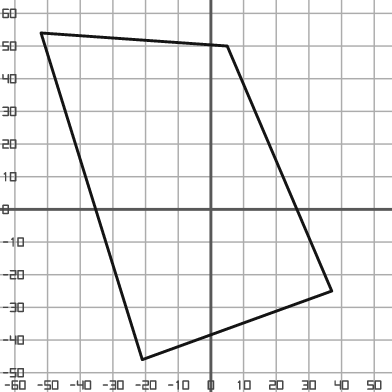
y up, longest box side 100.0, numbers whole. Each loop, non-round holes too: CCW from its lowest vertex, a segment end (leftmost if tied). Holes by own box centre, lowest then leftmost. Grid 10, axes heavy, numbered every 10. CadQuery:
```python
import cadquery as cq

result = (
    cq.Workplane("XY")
    .moveTo(-21.0, -46.0)
    .lineTo(37.0, -25.0)
    .lineTo(5.0, 50.0)
    .lineTo(-52.0, 54.0)
    .close()
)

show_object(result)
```